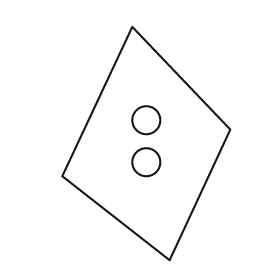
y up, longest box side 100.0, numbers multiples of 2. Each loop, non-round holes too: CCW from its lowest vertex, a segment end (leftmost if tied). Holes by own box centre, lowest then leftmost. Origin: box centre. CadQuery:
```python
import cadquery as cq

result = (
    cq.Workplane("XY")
    .moveTo(10.0, -50.0)
    .lineTo(36.0, 6.0)
    .lineTo(-6.0, 50.0)
    .lineTo(-36.0, -14.0)
    .close()
    .moveTo(0.0, -8.0)
    .circle(6.0)
    .moveTo(0.0, 10.0)
    .circle(6.0)
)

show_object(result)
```